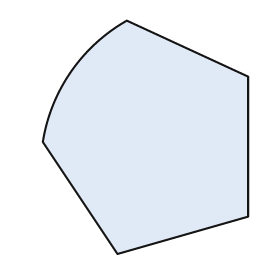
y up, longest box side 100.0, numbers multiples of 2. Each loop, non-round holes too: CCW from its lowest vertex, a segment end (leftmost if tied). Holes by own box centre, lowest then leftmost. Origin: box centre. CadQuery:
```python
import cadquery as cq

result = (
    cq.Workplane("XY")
    .moveTo(-12.0, -50.0)
    .lineTo(44.0, -34.0)
    .lineTo(44.0, 26.0)
    .lineTo(-8.0, 50.0)
    .threePointArc((-32.0, 28.0), (-44.0, -2.0))
    .close()
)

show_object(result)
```